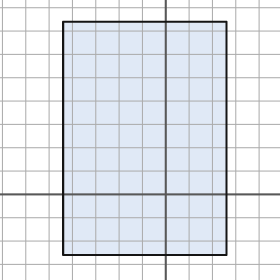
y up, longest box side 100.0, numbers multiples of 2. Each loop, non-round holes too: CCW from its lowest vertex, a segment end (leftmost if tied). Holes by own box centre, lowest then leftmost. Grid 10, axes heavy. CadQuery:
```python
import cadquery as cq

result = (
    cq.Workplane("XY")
    .moveTo(-44.0, -26.0)
    .lineTo(26.0, -26.0)
    .lineTo(26.0, 74.0)
    .lineTo(-44.0, 74.0)
    .close()
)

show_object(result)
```